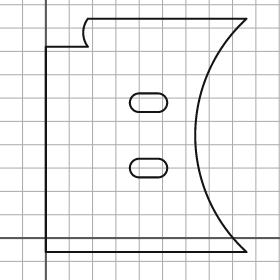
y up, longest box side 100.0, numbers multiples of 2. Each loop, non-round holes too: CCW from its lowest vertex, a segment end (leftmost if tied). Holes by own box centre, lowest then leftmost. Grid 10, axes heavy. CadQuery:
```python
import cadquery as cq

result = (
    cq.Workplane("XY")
    .moveTo(0.0, -6.0)
    .lineTo(86.0, -6.0)
    .threePointArc((64.0, 44.0), (86.0, 94.0))
    .lineTo(18.0, 94.0)
    .threePointArc((16.0, 88.0), (18.0, 82.0))
    .lineTo(0.0, 82.0)
    .close()
    .moveTo(40.0, 26.0)
    .lineTo(48.0, 26.0)
    .threePointArc((52.0, 30.0), (48.0, 34.0))
    .lineTo(40.0, 34.0)
    .threePointArc((36.0, 30.0), (40.0, 26.0))
    .close()
    .moveTo(40.0, 54.0)
    .lineTo(48.0, 54.0)
    .threePointArc((52.0, 58.0), (48.0, 62.0))
    .lineTo(40.0, 62.0)
    .threePointArc((36.0, 58.0), (40.0, 54.0))
    .close()
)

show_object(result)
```